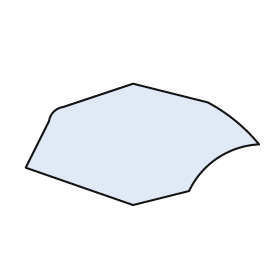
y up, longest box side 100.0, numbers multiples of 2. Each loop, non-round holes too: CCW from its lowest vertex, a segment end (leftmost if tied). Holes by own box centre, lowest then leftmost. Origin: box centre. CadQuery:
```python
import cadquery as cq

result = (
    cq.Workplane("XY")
    .moveTo(-4.0, -26.0)
    .lineTo(20.0, -20.0)
    .threePointArc((32.0, -6.0), (50.0, 0.0))
    .threePointArc((40.0, 10.0), (28.0, 18.0))
    .lineTo(-4.0, 26.0)
    .lineTo(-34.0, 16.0)
    .threePointArc((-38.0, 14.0), (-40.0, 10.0))
    .lineTo(-50.0, -10.0)
    .close()
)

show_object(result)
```